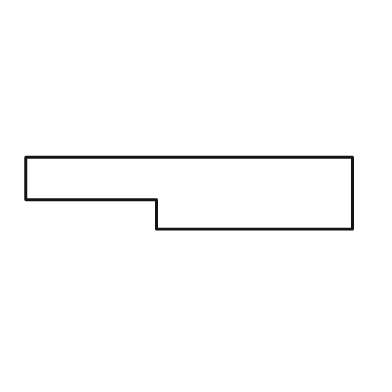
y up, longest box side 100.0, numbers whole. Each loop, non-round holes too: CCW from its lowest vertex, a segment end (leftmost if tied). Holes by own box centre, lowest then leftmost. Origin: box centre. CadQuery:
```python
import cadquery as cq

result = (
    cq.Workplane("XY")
    .moveTo(-10.0, -11.0)
    .lineTo(50.0, -11.0)
    .lineTo(50.0, 11.0)
    .lineTo(-50.0, 11.0)
    .lineTo(-50.0, -2.0)
    .lineTo(-10.0, -2.0)
    .close()
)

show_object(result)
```